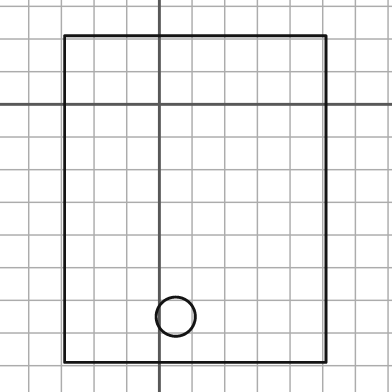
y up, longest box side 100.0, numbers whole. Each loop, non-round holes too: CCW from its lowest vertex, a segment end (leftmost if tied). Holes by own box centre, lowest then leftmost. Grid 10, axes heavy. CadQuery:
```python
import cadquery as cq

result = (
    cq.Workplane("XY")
    .moveTo(-29.0, -79.0)
    .lineTo(51.0, -79.0)
    .lineTo(51.0, 21.0)
    .lineTo(-29.0, 21.0)
    .close()
    .moveTo(5.0, -65.0)
    .circle(6.0)
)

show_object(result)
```